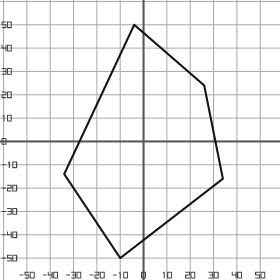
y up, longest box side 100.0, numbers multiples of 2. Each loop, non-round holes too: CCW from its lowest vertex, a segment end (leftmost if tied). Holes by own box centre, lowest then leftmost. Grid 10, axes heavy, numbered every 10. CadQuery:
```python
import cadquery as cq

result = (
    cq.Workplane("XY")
    .moveTo(-10.0, -50.0)
    .lineTo(34.0, -16.0)
    .lineTo(26.0, 24.0)
    .lineTo(-4.0, 50.0)
    .lineTo(-34.0, -14.0)
    .close()
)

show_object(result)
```